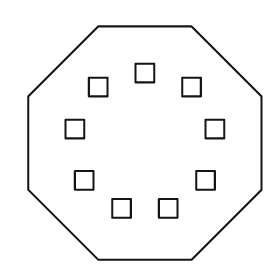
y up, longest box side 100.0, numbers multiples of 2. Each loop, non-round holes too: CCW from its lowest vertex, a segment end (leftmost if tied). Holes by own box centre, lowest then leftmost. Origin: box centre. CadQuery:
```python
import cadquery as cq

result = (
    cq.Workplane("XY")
    .moveTo(-20.0, -50.0)
    .lineTo(20.0, -50.0)
    .lineTo(50.0, -20.0)
    .lineTo(50.0, 20.0)
    .lineTo(20.0, 50.0)
    .lineTo(-20.0, 50.0)
    .lineTo(-50.0, 20.0)
    .lineTo(-50.0, -20.0)
    .close()
    .moveTo(-14.0, -32.0)
    .lineTo(-6.0, -32.0)
    .lineTo(-6.0, -24.0)
    .lineTo(-14.0, -24.0)
    .close()
    .moveTo(6.0, -32.0)
    .lineTo(14.0, -32.0)
    .lineTo(14.0, -24.0)
    .lineTo(6.0, -24.0)
    .close()
    .moveTo(-30.0, -20.0)
    .lineTo(-22.0, -20.0)
    .lineTo(-22.0, -12.0)
    .lineTo(-30.0, -12.0)
    .close()
    .moveTo(22.0, -20.0)
    .lineTo(30.0, -20.0)
    .lineTo(30.0, -12.0)
    .lineTo(22.0, -12.0)
    .close()
    .moveTo(-34.0, 2.0)
    .lineTo(-26.0, 2.0)
    .lineTo(-26.0, 10.0)
    .lineTo(-34.0, 10.0)
    .close()
    .moveTo(26.0, 2.0)
    .lineTo(34.0, 2.0)
    .lineTo(34.0, 10.0)
    .lineTo(26.0, 10.0)
    .close()
    .moveTo(-24.0, 20.0)
    .lineTo(-16.0, 20.0)
    .lineTo(-16.0, 28.0)
    .lineTo(-24.0, 28.0)
    .close()
    .moveTo(16.0, 20.0)
    .lineTo(24.0, 20.0)
    .lineTo(24.0, 28.0)
    .lineTo(16.0, 28.0)
    .close()
    .moveTo(-4.0, 26.0)
    .lineTo(4.0, 26.0)
    .lineTo(4.0, 34.0)
    .lineTo(-4.0, 34.0)
    .close()
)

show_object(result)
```